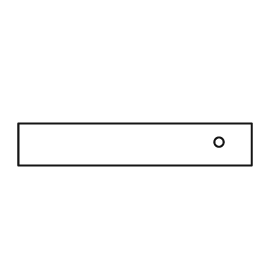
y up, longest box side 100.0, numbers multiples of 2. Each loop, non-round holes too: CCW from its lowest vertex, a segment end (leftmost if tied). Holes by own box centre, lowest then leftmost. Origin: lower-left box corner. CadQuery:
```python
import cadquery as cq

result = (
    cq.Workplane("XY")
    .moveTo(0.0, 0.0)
    .lineTo(100.0, 0.0)
    .lineTo(100.0, 18.0)
    .lineTo(0.0, 18.0)
    .close()
    .moveTo(86.0, 10.0)
    .circle(2.0)
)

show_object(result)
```